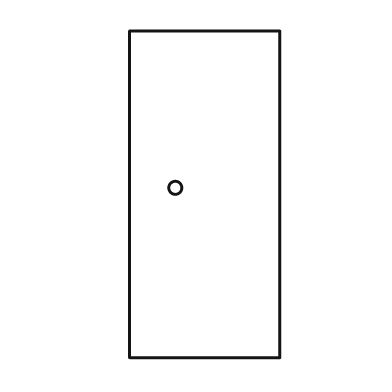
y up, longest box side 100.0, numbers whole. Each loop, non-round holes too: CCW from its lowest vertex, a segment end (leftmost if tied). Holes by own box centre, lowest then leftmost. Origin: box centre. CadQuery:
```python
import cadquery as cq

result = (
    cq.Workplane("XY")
    .moveTo(-23.0, -50.0)
    .lineTo(23.0, -50.0)
    .lineTo(23.0, 50.0)
    .lineTo(-23.0, 50.0)
    .close()
    .moveTo(-9.0, 2.0)
    .circle(2.0)
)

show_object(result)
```